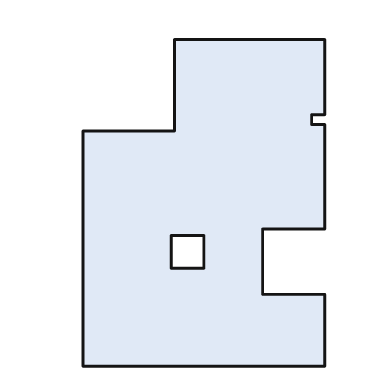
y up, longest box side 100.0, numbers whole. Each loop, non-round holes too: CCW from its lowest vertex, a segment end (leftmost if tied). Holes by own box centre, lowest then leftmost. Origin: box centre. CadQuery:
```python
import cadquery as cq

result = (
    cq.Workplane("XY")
    .moveTo(-37.0, -50.0)
    .lineTo(37.0, -50.0)
    .lineTo(37.0, -28.0)
    .lineTo(18.0, -28.0)
    .lineTo(18.0, -8.0)
    .lineTo(37.0, -8.0)
    .lineTo(37.0, 24.0)
    .lineTo(33.0, 24.0)
    .lineTo(33.0, 27.0)
    .lineTo(37.0, 27.0)
    .lineTo(37.0, 50.0)
    .lineTo(-9.0, 50.0)
    .lineTo(-9.0, 22.0)
    .lineTo(-37.0, 22.0)
    .close()
    .moveTo(-10.0, -20.0)
    .lineTo(0.0, -20.0)
    .lineTo(0.0, -10.0)
    .lineTo(-10.0, -10.0)
    .close()
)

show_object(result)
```